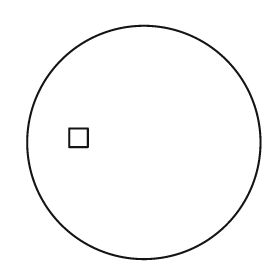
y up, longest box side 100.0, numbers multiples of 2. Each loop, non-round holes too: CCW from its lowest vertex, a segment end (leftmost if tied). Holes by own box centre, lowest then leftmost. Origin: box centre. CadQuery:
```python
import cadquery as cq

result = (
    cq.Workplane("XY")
    .moveTo(0.0, 0.0)
    .circle(50.0)
    .moveTo(-32.0, -2.0)
    .lineTo(-24.0, -2.0)
    .lineTo(-24.0, 6.0)
    .lineTo(-32.0, 6.0)
    .close()
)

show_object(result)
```